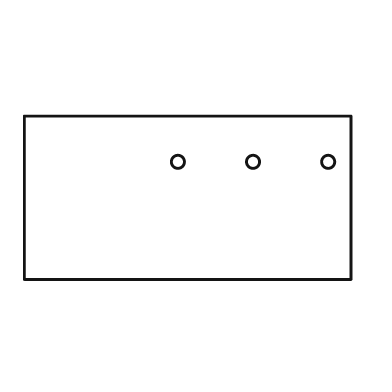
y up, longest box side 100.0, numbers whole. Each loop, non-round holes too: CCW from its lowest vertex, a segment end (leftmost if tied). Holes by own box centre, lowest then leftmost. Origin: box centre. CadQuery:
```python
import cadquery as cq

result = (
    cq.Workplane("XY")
    .moveTo(-50.0, -25.0)
    .lineTo(50.0, -25.0)
    .lineTo(50.0, 25.0)
    .lineTo(-50.0, 25.0)
    .close()
    .moveTo(-3.0, 11.0)
    .circle(2.0)
    .moveTo(20.0, 11.0)
    .circle(2.0)
    .moveTo(43.0, 11.0)
    .circle(2.0)
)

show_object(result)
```